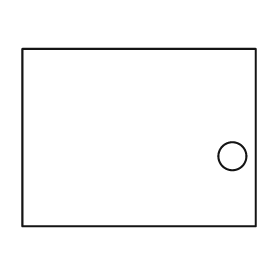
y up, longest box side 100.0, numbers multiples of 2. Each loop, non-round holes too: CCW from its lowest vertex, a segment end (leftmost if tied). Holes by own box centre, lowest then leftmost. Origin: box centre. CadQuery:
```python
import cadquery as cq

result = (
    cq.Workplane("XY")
    .moveTo(-50.0, -38.0)
    .lineTo(50.0, -38.0)
    .lineTo(50.0, 38.0)
    .lineTo(-50.0, 38.0)
    .close()
    .moveTo(40.0, -8.0)
    .circle(6.0)
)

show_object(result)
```